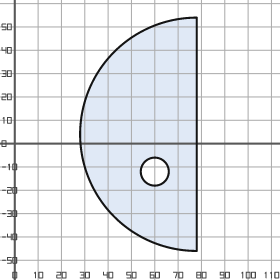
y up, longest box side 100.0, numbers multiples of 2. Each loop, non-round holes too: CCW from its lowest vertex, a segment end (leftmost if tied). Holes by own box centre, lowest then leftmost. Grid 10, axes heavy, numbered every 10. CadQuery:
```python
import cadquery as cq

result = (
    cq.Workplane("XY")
    .moveTo(78.0, -46.0)
    .lineTo(78.0, 54.0)
    .threePointArc((28.0, 4.0), (78.0, -46.0))
    .close()
    .moveTo(60.0, -12.0)
    .circle(6.0)
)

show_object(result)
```